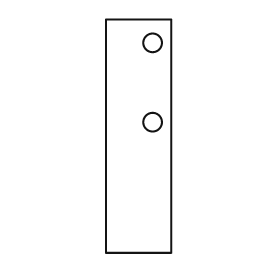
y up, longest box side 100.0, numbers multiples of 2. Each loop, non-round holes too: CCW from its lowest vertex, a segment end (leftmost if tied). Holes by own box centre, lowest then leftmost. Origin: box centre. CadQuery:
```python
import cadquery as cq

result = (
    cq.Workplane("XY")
    .moveTo(-14.0, -50.0)
    .lineTo(14.0, -50.0)
    .lineTo(14.0, 50.0)
    .lineTo(-14.0, 50.0)
    .close()
    .moveTo(6.0, 6.0)
    .circle(4.0)
    .moveTo(6.0, 40.0)
    .circle(4.0)
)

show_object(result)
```